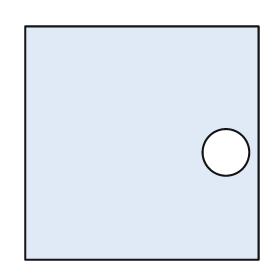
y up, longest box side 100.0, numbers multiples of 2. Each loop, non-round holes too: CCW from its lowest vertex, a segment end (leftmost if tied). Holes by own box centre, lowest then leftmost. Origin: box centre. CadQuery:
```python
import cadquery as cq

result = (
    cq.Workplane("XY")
    .moveTo(-50.0, -50.0)
    .lineTo(50.0, -50.0)
    .lineTo(50.0, 50.0)
    .lineTo(-50.0, 50.0)
    .close()
    .moveTo(36.0, -4.0)
    .circle(10.0)
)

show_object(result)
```